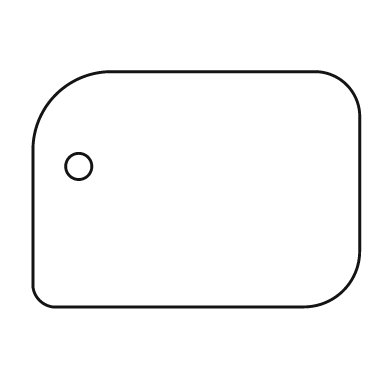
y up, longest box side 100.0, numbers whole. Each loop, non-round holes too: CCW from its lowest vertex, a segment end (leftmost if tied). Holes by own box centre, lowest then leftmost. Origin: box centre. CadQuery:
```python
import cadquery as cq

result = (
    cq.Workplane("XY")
    .moveTo(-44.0, -36.0)
    .lineTo(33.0, -36.0)
    .threePointArc((45.0, -31.0), (50.0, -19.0))
    .lineTo(50.0, 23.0)
    .threePointArc((46.0, 32.0), (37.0, 36.0))
    .lineTo(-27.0, 36.0)
    .threePointArc((-43.0, 29.0), (-50.0, 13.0))
    .lineTo(-50.0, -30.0)
    .threePointArc((-48.0, -34.0), (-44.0, -36.0))
    .close()
    .moveTo(-36.0, 7.0)
    .circle(4.0)
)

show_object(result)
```